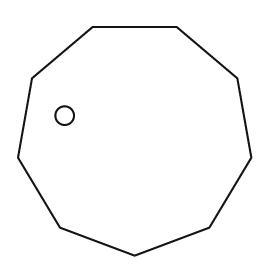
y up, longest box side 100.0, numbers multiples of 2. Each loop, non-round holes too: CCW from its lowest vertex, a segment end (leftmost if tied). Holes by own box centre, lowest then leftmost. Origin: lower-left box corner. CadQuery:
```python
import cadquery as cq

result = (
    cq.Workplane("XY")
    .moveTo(50.0, 0.0)
    .lineTo(82.0, 12.0)
    .lineTo(100.0, 42.0)
    .lineTo(94.0, 76.0)
    .lineTo(68.0, 98.0)
    .lineTo(32.0, 98.0)
    .lineTo(6.0, 76.0)
    .lineTo(0.0, 42.0)
    .lineTo(18.0, 12.0)
    .close()
    .moveTo(20.0, 60.0)
    .circle(4.0)
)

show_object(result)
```